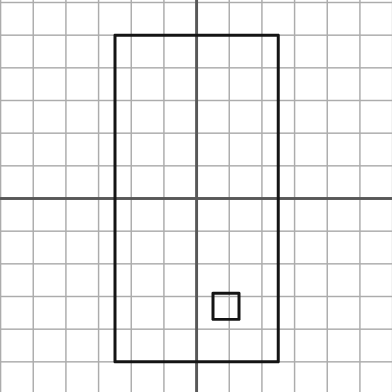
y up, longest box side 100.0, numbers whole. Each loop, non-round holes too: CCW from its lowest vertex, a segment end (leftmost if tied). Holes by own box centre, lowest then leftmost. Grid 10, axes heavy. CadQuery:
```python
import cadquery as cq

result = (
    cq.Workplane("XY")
    .moveTo(-25.0, -50.0)
    .lineTo(25.0, -50.0)
    .lineTo(25.0, 50.0)
    .lineTo(-25.0, 50.0)
    .close()
    .moveTo(5.0, -37.0)
    .lineTo(13.0, -37.0)
    .lineTo(13.0, -29.0)
    .lineTo(5.0, -29.0)
    .close()
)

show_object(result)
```